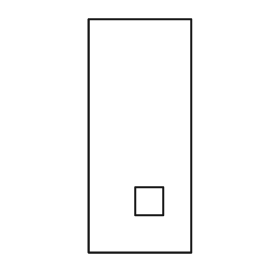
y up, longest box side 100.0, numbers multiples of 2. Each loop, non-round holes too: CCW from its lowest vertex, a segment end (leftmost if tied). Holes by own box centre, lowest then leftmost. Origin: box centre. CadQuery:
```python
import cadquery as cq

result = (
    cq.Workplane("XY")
    .moveTo(-22.0, -50.0)
    .lineTo(22.0, -50.0)
    .lineTo(22.0, 50.0)
    .lineTo(-22.0, 50.0)
    .close()
    .moveTo(-2.0, -34.0)
    .lineTo(10.0, -34.0)
    .lineTo(10.0, -22.0)
    .lineTo(-2.0, -22.0)
    .close()
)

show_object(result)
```